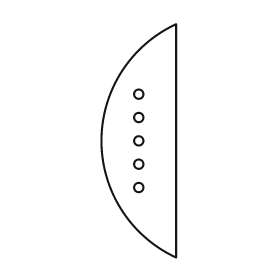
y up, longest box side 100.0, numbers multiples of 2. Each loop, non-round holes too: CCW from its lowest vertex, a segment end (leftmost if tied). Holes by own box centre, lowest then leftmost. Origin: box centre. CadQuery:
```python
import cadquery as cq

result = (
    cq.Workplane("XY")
    .moveTo(16.0, -50.0)
    .lineTo(16.0, 50.0)
    .threePointArc((-16.0, 0.0), (16.0, -50.0))
    .close()
    .moveTo(0.0, -20.0)
    .circle(2.0)
    .moveTo(0.0, -10.0)
    .circle(2.0)
    .moveTo(0.0, 0.0)
    .circle(2.0)
    .moveTo(0.0, 10.0)
    .circle(2.0)
    .moveTo(0.0, 20.0)
    .circle(2.0)
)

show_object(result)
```